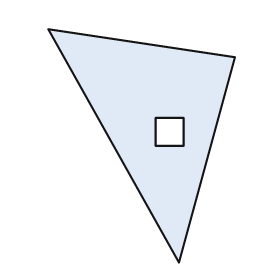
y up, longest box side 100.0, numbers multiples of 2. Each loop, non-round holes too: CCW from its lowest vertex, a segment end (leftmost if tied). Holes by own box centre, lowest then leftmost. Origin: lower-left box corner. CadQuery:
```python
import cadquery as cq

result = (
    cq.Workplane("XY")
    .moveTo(56.0, 0.0)
    .lineTo(80.0, 88.0)
    .lineTo(0.0, 100.0)
    .close()
    .moveTo(46.0, 50.0)
    .lineTo(58.0, 50.0)
    .lineTo(58.0, 62.0)
    .lineTo(46.0, 62.0)
    .close()
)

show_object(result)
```